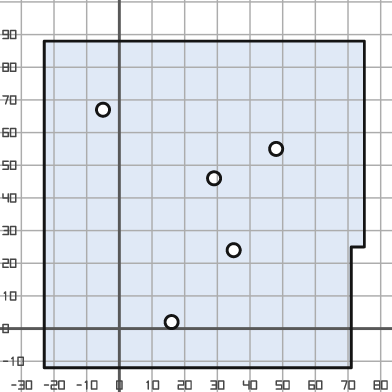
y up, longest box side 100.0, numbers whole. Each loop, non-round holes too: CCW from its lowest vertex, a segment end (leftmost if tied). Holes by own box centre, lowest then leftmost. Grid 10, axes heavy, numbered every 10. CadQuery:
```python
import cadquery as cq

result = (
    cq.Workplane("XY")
    .moveTo(-23.0, -12.0)
    .lineTo(71.0, -12.0)
    .lineTo(71.0, 25.0)
    .lineTo(75.0, 25.0)
    .lineTo(75.0, 88.0)
    .lineTo(-23.0, 88.0)
    .close()
    .moveTo(16.0, 2.0)
    .circle(2.0)
    .moveTo(35.0, 24.0)
    .circle(2.0)
    .moveTo(29.0, 46.0)
    .circle(2.0)
    .moveTo(48.0, 55.0)
    .circle(2.0)
    .moveTo(-5.0, 67.0)
    .circle(2.0)
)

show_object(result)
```